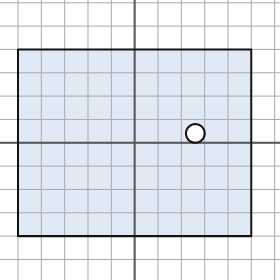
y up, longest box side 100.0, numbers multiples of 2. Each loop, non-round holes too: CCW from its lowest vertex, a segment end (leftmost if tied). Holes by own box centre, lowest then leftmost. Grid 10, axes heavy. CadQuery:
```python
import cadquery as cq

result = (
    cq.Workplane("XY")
    .moveTo(-50.0, -40.0)
    .lineTo(50.0, -40.0)
    .lineTo(50.0, 40.0)
    .lineTo(-50.0, 40.0)
    .close()
    .moveTo(26.0, 4.0)
    .circle(4.0)
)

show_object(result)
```